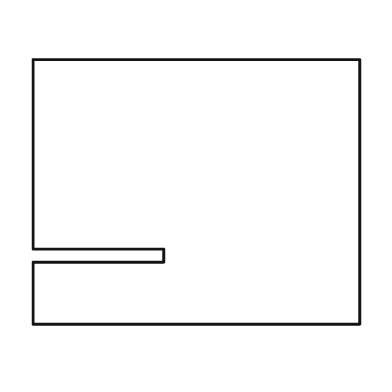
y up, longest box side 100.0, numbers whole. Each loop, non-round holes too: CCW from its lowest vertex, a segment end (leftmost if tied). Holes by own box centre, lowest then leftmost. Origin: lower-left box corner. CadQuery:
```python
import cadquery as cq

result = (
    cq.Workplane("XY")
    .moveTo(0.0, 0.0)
    .lineTo(100.0, 0.0)
    .lineTo(100.0, 81.0)
    .lineTo(0.0, 81.0)
    .lineTo(0.0, 23.0)
    .lineTo(40.0, 23.0)
    .lineTo(40.0, 19.0)
    .lineTo(0.0, 19.0)
    .close()
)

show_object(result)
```